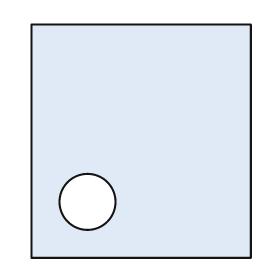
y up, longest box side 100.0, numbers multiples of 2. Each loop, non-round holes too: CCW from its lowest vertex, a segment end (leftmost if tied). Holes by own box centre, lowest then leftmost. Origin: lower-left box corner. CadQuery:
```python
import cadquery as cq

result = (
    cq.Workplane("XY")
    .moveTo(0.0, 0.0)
    .lineTo(94.0, 0.0)
    .lineTo(94.0, 100.0)
    .lineTo(0.0, 100.0)
    .close()
    .moveTo(24.0, 24.0)
    .circle(12.0)
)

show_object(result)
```